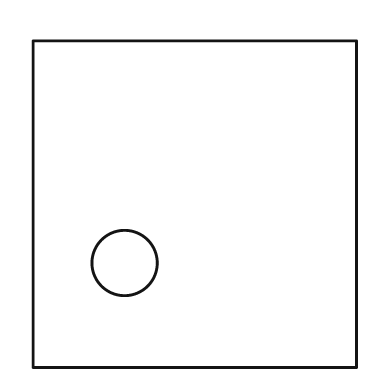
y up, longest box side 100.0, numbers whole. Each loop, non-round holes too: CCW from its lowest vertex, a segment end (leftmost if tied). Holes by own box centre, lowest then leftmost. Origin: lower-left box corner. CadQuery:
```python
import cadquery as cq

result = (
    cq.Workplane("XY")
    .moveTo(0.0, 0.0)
    .lineTo(99.0, 0.0)
    .lineTo(99.0, 100.0)
    .lineTo(0.0, 100.0)
    .close()
    .moveTo(28.0, 32.0)
    .circle(10.0)
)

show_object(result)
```